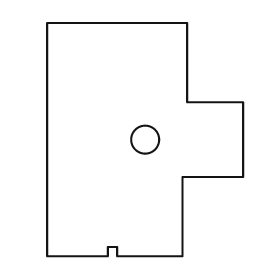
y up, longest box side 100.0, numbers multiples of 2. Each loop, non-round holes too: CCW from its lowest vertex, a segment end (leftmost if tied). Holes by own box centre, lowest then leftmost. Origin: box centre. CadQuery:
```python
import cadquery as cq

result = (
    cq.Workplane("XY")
    .moveTo(-42.0, -50.0)
    .lineTo(-16.0, -50.0)
    .lineTo(-16.0, -46.0)
    .lineTo(-12.0, -46.0)
    .lineTo(-12.0, -50.0)
    .lineTo(16.0, -50.0)
    .lineTo(16.0, -16.0)
    .lineTo(42.0, -16.0)
    .lineTo(42.0, 16.0)
    .lineTo(18.0, 16.0)
    .lineTo(18.0, 50.0)
    .lineTo(-42.0, 50.0)
    .close()
    .moveTo(0.0, 0.0)
    .circle(6.0)
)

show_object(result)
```